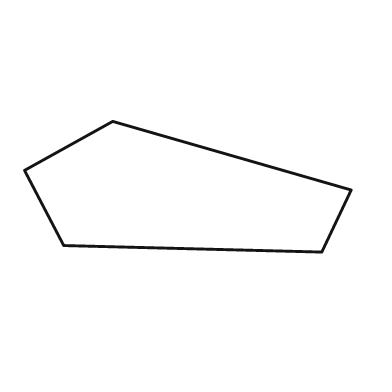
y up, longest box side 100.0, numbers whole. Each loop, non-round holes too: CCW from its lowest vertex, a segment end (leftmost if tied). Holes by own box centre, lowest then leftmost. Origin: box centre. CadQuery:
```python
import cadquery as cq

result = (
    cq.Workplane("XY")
    .moveTo(41.0, -20.0)
    .lineTo(50.0, -1.0)
    .lineTo(-23.0, 20.0)
    .lineTo(-50.0, 5.0)
    .lineTo(-38.0, -18.0)
    .close()
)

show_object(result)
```